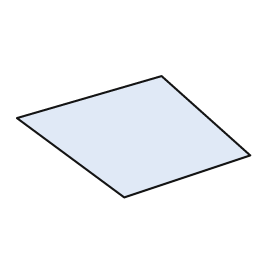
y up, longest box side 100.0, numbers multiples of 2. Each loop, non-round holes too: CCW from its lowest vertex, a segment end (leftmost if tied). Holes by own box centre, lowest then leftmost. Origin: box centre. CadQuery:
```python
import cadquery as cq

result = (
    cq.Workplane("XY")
    .moveTo(-4.0, -26.0)
    .lineTo(50.0, -8.0)
    .lineTo(12.0, 26.0)
    .lineTo(-50.0, 8.0)
    .close()
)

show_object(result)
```